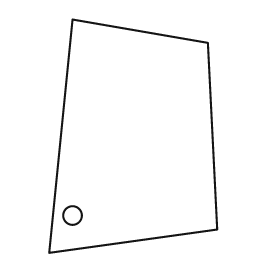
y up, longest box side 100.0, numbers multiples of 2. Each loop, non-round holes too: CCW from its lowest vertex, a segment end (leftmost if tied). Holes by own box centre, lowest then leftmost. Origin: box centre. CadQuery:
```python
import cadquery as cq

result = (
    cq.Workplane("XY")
    .moveTo(-36.0, -50.0)
    .lineTo(36.0, -40.0)
    .lineTo(32.0, 40.0)
    .lineTo(-26.0, 50.0)
    .close()
    .moveTo(-26.0, -34.0)
    .circle(4.0)
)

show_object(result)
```